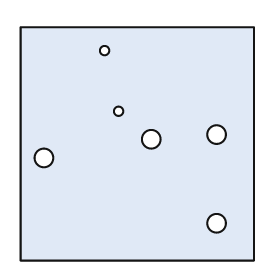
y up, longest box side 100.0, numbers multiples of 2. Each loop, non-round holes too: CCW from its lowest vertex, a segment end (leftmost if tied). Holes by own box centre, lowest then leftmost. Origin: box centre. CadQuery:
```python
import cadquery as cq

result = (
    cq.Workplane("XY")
    .moveTo(-50.0, -50.0)
    .lineTo(50.0, -50.0)
    .lineTo(50.0, 50.0)
    .lineTo(-50.0, 50.0)
    .close()
    .moveTo(34.0, -34.0)
    .circle(4.0)
    .moveTo(-40.0, -6.0)
    .circle(4.0)
    .moveTo(6.0, 2.0)
    .circle(4.0)
    .moveTo(34.0, 4.0)
    .circle(4.0)
    .moveTo(-8.0, 14.0)
    .circle(2.0)
    .moveTo(-14.0, 40.0)
    .circle(2.0)
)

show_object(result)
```